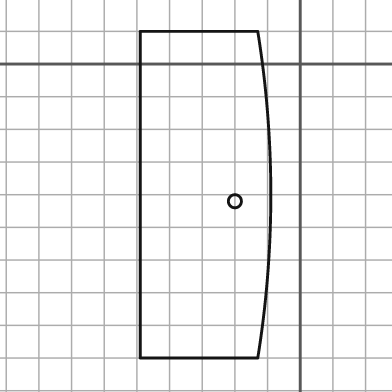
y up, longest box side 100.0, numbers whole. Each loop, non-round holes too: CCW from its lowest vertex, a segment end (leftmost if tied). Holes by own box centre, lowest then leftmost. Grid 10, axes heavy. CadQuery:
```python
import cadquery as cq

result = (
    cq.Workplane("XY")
    .moveTo(-49.0, -90.0)
    .lineTo(-13.0, -90.0)
    .threePointArc((-9.0, -40.0), (-13.0, 10.0))
    .lineTo(-49.0, 10.0)
    .close()
    .moveTo(-20.0, -42.0)
    .circle(2.0)
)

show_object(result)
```